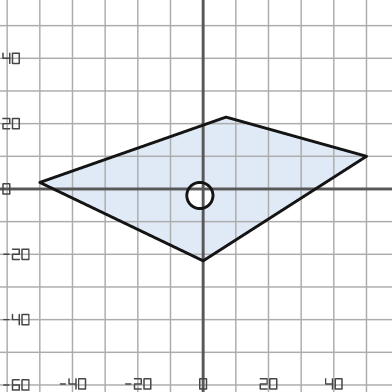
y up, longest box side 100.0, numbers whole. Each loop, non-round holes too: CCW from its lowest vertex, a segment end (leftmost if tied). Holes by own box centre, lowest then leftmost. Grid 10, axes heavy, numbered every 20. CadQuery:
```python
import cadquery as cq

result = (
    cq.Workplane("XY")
    .moveTo(0.0, -22.0)
    .lineTo(50.0, 10.0)
    .lineTo(7.0, 22.0)
    .lineTo(-50.0, 2.0)
    .close()
    .moveTo(-1.0, -2.0)
    .circle(4.0)
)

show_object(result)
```